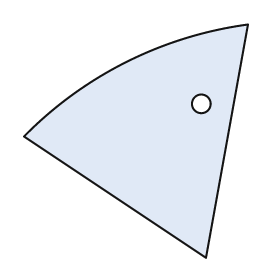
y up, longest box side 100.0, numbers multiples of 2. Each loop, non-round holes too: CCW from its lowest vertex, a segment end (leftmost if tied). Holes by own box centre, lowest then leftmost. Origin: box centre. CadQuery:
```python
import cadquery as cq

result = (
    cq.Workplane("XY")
    .moveTo(30.0, -50.0)
    .lineTo(48.0, 50.0)
    .threePointArc((-4.0, 34.0), (-48.0, 2.0))
    .close()
    .moveTo(28.0, 16.0)
    .circle(4.0)
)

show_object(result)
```